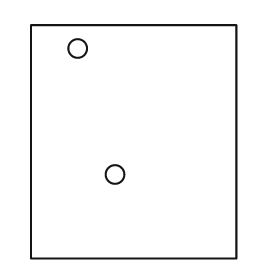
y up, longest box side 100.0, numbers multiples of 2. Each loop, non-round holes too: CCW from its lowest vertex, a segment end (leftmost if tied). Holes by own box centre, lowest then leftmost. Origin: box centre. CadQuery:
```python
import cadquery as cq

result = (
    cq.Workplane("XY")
    .moveTo(-44.0, -50.0)
    .lineTo(44.0, -50.0)
    .lineTo(44.0, 50.0)
    .lineTo(-44.0, 50.0)
    .close()
    .moveTo(-8.0, -14.0)
    .circle(4.0)
    .moveTo(-24.0, 40.0)
    .circle(4.0)
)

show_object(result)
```